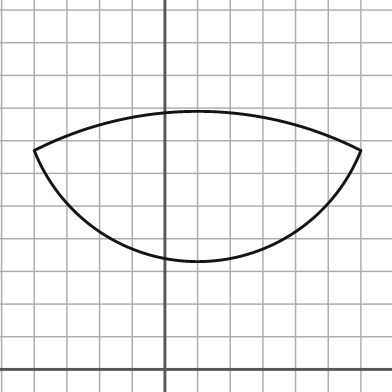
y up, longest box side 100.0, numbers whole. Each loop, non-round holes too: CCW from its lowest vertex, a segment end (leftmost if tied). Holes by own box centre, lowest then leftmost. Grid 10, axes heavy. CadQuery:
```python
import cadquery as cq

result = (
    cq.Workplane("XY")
    .moveTo(-40.0, 67.0)
    .threePointArc((10.0, 33.0), (60.0, 67.0))
    .threePointArc((10.0, 79.0), (-40.0, 67.0))
    .close()
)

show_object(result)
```